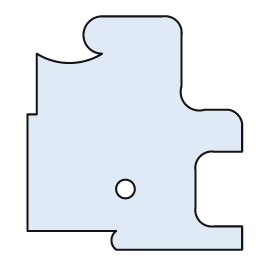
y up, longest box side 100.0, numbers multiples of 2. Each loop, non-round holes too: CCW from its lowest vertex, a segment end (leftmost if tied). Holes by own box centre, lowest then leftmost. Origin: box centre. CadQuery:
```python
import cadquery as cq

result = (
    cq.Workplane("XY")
    .moveTo(-8.0, -50.0)
    .lineTo(46.0, -50.0)
    .lineTo(46.0, -40.0)
    .lineTo(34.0, -40.0)
    .threePointArc((28.0, -38.0), (26.0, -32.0))
    .lineTo(26.0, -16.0)
    .threePointArc((28.0, -10.0), (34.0, -8.0))
    .lineTo(46.0, -8.0)
    .lineTo(46.0, 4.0)
    .threePointArc((44.0, 8.0), (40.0, 10.0))
    .lineTo(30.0, 10.0)
    .threePointArc((22.0, 12.0), (20.0, 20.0))
    .lineTo(20.0, 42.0)
    .threePointArc((18.0, 48.0), (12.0, 50.0))
    .lineTo(-14.0, 50.0)
    .threePointArc((-22.0, 42.0), (-14.0, 34.0))
    .threePointArc((-28.0, 30.0), (-42.0, 34.0))
    .lineTo(-42.0, 8.0)
    .lineTo(-46.0, 8.0)
    .lineTo(-46.0, -42.0)
    .lineTo(-8.0, -42.0)
    .threePointArc((-10.0, -46.0), (-8.0, -50.0))
    .close()
    .moveTo(-4.0, -24.0)
    .circle(4.0)
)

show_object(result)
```